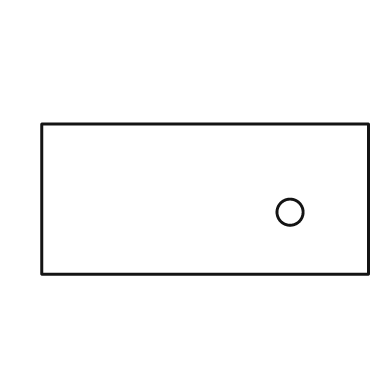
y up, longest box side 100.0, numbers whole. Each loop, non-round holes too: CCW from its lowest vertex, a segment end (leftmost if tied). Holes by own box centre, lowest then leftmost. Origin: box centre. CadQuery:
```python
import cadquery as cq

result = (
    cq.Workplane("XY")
    .moveTo(-50.0, -23.0)
    .lineTo(50.0, -23.0)
    .lineTo(50.0, 23.0)
    .lineTo(-50.0, 23.0)
    .close()
    .moveTo(26.0, -4.0)
    .circle(4.0)
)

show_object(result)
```